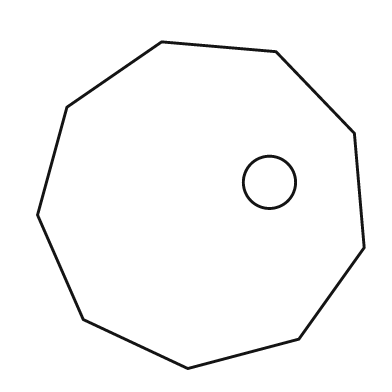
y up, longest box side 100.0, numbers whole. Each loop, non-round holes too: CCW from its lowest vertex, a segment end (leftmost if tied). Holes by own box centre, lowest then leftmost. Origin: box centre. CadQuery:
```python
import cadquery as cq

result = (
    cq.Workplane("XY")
    .moveTo(-4.0, -50.0)
    .lineTo(30.0, -41.0)
    .lineTo(50.0, -13.0)
    .lineTo(47.0, 22.0)
    .lineTo(23.0, 47.0)
    .lineTo(-12.0, 50.0)
    .lineTo(-41.0, 30.0)
    .lineTo(-50.0, -3.0)
    .lineTo(-36.0, -35.0)
    .close()
    .moveTo(21.0, 7.0)
    .circle(8.0)
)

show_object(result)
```